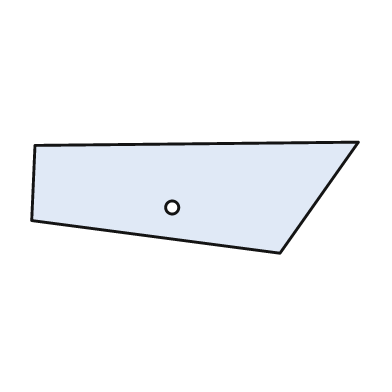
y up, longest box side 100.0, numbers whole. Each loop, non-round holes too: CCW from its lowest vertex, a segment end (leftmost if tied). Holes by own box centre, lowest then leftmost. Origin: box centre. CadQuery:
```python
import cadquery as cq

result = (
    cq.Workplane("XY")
    .moveTo(26.0, -17.0)
    .lineTo(50.0, 17.0)
    .lineTo(-49.0, 16.0)
    .lineTo(-50.0, -7.0)
    .close()
    .moveTo(-7.0, -3.0)
    .circle(2.0)
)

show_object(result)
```